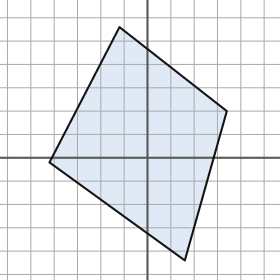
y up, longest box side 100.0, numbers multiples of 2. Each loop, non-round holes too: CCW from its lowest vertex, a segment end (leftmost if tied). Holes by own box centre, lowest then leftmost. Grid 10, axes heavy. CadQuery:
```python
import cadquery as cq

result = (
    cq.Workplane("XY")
    .moveTo(16.0, -44.0)
    .lineTo(34.0, 20.0)
    .lineTo(-12.0, 56.0)
    .lineTo(-42.0, -2.0)
    .close()
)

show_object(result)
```